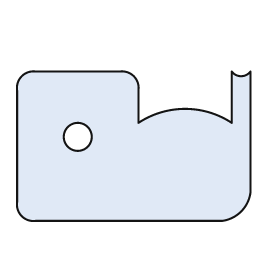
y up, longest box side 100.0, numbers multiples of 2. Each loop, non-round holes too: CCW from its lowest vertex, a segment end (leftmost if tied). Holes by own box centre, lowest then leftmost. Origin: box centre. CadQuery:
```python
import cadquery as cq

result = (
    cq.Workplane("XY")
    .moveTo(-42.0, -32.0)
    .lineTo(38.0, -32.0)
    .threePointArc((46.0, -28.0), (50.0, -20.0))
    .lineTo(50.0, 32.0)
    .threePointArc((46.0, 30.0), (42.0, 32.0))
    .lineTo(42.0, 10.0)
    .threePointArc((22.0, 16.0), (2.0, 10.0))
    .lineTo(2.0, 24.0)
    .threePointArc((0.0, 30.0), (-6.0, 32.0))
    .lineTo(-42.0, 32.0)
    .threePointArc((-48.0, 30.0), (-50.0, 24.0))
    .lineTo(-50.0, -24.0)
    .threePointArc((-48.0, -30.0), (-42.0, -32.0))
    .close()
    .moveTo(-24.0, 4.0)
    .circle(6.0)
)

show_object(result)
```